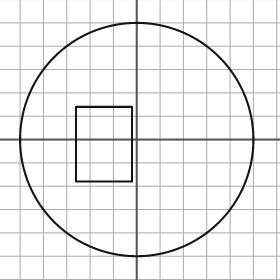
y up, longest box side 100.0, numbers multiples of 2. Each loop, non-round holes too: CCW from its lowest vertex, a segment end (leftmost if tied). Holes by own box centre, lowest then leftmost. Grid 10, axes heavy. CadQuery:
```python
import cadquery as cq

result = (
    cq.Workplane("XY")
    .moveTo(0.0, 0.0)
    .circle(50.0)
    .moveTo(-26.0, -18.0)
    .lineTo(-2.0, -18.0)
    .lineTo(-2.0, 14.0)
    .lineTo(-26.0, 14.0)
    .close()
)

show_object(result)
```